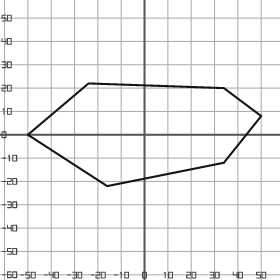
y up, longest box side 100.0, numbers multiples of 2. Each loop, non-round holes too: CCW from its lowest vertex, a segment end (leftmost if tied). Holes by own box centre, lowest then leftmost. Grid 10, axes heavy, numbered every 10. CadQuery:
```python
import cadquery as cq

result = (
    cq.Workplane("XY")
    .moveTo(-16.0, -22.0)
    .lineTo(34.0, -12.0)
    .lineTo(50.0, 8.0)
    .lineTo(34.0, 20.0)
    .lineTo(-24.0, 22.0)
    .lineTo(-50.0, 0.0)
    .close()
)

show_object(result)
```